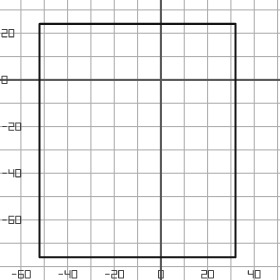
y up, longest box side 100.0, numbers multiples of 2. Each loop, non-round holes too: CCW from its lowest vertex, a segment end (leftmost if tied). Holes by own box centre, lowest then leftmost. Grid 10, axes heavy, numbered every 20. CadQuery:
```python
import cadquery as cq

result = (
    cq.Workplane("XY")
    .moveTo(-52.0, -76.0)
    .lineTo(32.0, -76.0)
    .lineTo(32.0, 24.0)
    .lineTo(-52.0, 24.0)
    .close()
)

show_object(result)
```